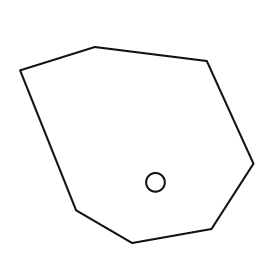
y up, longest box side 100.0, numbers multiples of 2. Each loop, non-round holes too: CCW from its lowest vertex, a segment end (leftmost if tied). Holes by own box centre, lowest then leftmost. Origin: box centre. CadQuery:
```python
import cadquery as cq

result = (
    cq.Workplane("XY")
    .moveTo(-2.0, -42.0)
    .lineTo(32.0, -36.0)
    .lineTo(50.0, -8.0)
    .lineTo(30.0, 36.0)
    .lineTo(-18.0, 42.0)
    .lineTo(-50.0, 32.0)
    .lineTo(-26.0, -28.0)
    .close()
    .moveTo(8.0, -16.0)
    .circle(4.0)
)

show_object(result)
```